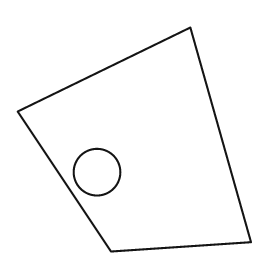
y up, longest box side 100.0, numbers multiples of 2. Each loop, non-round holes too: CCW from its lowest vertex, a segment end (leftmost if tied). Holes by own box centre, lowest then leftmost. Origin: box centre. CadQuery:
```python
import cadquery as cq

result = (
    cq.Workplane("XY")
    .moveTo(-10.0, -48.0)
    .lineTo(50.0, -44.0)
    .lineTo(24.0, 48.0)
    .lineTo(-50.0, 12.0)
    .close()
    .moveTo(-16.0, -14.0)
    .circle(10.0)
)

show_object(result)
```